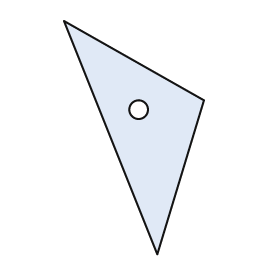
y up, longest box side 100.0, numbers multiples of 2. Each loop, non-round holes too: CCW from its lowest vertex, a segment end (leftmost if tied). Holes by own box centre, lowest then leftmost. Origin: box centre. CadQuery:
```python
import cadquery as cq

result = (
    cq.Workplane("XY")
    .moveTo(10.0, -50.0)
    .lineTo(30.0, 16.0)
    .lineTo(-30.0, 50.0)
    .close()
    .moveTo(2.0, 12.0)
    .circle(4.0)
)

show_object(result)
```